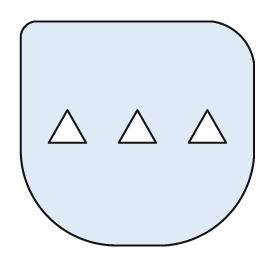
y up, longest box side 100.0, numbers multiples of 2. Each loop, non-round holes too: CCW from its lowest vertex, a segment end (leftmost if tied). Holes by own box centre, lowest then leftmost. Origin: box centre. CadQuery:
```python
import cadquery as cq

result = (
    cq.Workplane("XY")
    .moveTo(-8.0, -48.0)
    .lineTo(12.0, -48.0)
    .threePointArc((38.0, -36.0), (50.0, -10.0))
    .lineTo(50.0, 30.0)
    .threePointArc((44.0, 42.0), (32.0, 48.0))
    .lineTo(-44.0, 48.0)
    .threePointArc((-48.0, 46.0), (-50.0, 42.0))
    .lineTo(-50.0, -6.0)
    .threePointArc((-38.0, -36.0), (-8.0, -48.0))
    .close()
    .moveTo(-38.0, -4.0)
    .lineTo(-22.0, -4.0)
    .lineTo(-30.0, 10.0)
    .close()
    .moveTo(-8.0, -4.0)
    .lineTo(8.0, -4.0)
    .lineTo(0.0, 10.0)
    .close()
    .moveTo(22.0, -4.0)
    .lineTo(38.0, -4.0)
    .lineTo(30.0, 10.0)
    .close()
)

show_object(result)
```